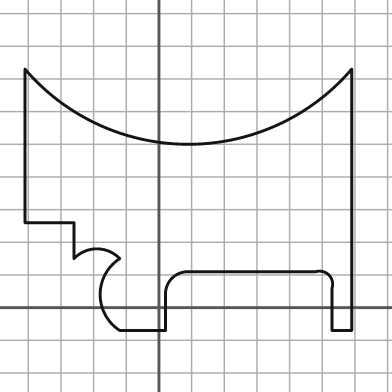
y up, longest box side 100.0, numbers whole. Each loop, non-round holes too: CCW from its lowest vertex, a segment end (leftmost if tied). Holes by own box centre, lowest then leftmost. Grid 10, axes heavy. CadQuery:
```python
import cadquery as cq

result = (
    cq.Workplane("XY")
    .moveTo(-12.0, -7.0)
    .lineTo(2.0, -7.0)
    .lineTo(2.0, 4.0)
    .threePointArc((4.0, 9.0), (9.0, 11.0))
    .lineTo(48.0, 11.0)
    .threePointArc((52.0, 10.0), (53.0, 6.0))
    .lineTo(53.0, -7.0)
    .lineTo(59.0, -7.0)
    .lineTo(59.0, 73.0)
    .threePointArc((9.0, 50.0), (-41.0, 73.0))
    .lineTo(-41.0, 26.0)
    .lineTo(-26.0, 26.0)
    .lineTo(-26.0, 15.0)
    .threePointArc((-19.0, 18.0), (-12.0, 15.0))
    .threePointArc((-18.0, 4.0), (-12.0, -7.0))
    .close()
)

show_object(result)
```